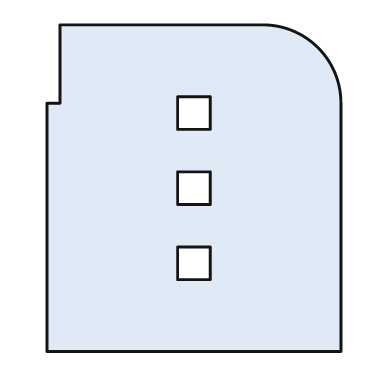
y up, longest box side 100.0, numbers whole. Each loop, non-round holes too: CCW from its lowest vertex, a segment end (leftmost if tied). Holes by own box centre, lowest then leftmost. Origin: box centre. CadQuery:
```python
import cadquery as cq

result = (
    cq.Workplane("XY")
    .moveTo(-45.0, -50.0)
    .lineTo(45.0, -50.0)
    .lineTo(45.0, 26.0)
    .threePointArc((38.0, 43.0), (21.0, 50.0))
    .lineTo(-41.0, 50.0)
    .lineTo(-41.0, 26.0)
    .lineTo(-45.0, 26.0)
    .close()
    .moveTo(-5.0, -28.0)
    .lineTo(5.0, -28.0)
    .lineTo(5.0, -18.0)
    .lineTo(-5.0, -18.0)
    .close()
    .moveTo(-5.0, -5.0)
    .lineTo(5.0, -5.0)
    .lineTo(5.0, 5.0)
    .lineTo(-5.0, 5.0)
    .close()
    .moveTo(-5.0, 18.0)
    .lineTo(5.0, 18.0)
    .lineTo(5.0, 28.0)
    .lineTo(-5.0, 28.0)
    .close()
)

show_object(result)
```